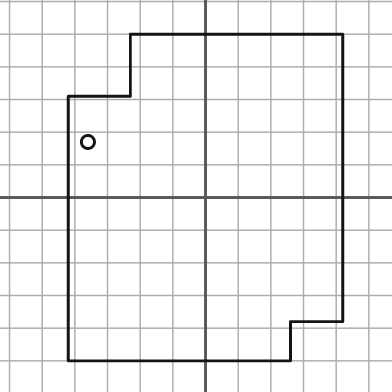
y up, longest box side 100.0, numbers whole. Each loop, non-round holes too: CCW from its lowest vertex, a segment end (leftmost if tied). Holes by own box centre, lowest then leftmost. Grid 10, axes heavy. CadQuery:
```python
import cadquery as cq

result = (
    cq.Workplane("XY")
    .moveTo(-42.0, -50.0)
    .lineTo(26.0, -50.0)
    .lineTo(26.0, -38.0)
    .lineTo(42.0, -38.0)
    .lineTo(42.0, 50.0)
    .lineTo(-23.0, 50.0)
    .lineTo(-23.0, 31.0)
    .lineTo(-42.0, 31.0)
    .close()
    .moveTo(-36.0, 17.0)
    .circle(2.0)
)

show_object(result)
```